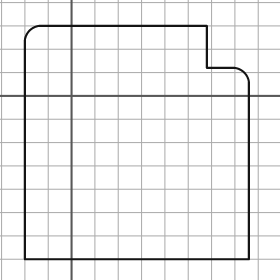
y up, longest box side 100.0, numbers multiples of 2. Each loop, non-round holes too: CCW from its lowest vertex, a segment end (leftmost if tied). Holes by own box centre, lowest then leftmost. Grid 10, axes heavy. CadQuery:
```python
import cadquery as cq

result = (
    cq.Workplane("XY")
    .moveTo(-20.0, -70.0)
    .lineTo(76.0, -70.0)
    .lineTo(76.0, 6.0)
    .threePointArc((74.0, 10.0), (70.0, 12.0))
    .lineTo(58.0, 12.0)
    .lineTo(58.0, 30.0)
    .lineTo(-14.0, 30.0)
    .threePointArc((-18.0, 28.0), (-20.0, 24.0))
    .close()
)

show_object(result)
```